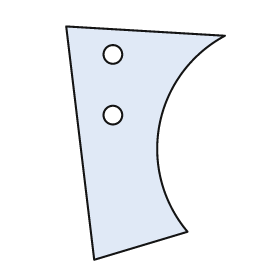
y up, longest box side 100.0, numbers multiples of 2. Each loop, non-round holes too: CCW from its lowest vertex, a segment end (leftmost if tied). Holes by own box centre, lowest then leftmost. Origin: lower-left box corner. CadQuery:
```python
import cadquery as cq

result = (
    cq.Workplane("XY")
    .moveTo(12.0, 0.0)
    .lineTo(52.0, 12.0)
    .threePointArc((40.0, 58.0), (68.0, 96.0))
    .lineTo(0.0, 100.0)
    .close()
    .moveTo(20.0, 62.0)
    .circle(4.0)
    .moveTo(20.0, 88.0)
    .circle(4.0)
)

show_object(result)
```